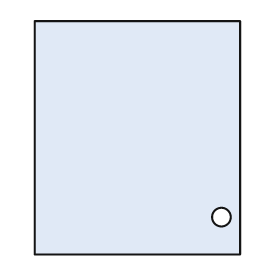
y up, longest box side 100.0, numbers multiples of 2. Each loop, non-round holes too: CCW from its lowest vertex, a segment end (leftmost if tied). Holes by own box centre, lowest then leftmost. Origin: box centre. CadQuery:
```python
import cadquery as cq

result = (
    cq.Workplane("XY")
    .moveTo(-44.0, -50.0)
    .lineTo(44.0, -50.0)
    .lineTo(44.0, 50.0)
    .lineTo(-44.0, 50.0)
    .close()
    .moveTo(36.0, -34.0)
    .circle(4.0)
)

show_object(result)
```